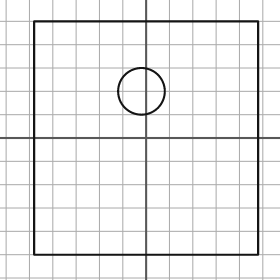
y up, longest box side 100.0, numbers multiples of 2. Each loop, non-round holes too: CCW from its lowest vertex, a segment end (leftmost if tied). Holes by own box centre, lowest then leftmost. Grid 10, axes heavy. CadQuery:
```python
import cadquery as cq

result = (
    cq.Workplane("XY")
    .moveTo(-48.0, -50.0)
    .lineTo(48.0, -50.0)
    .lineTo(48.0, 50.0)
    .lineTo(-48.0, 50.0)
    .close()
    .moveTo(-2.0, 20.0)
    .circle(10.0)
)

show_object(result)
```